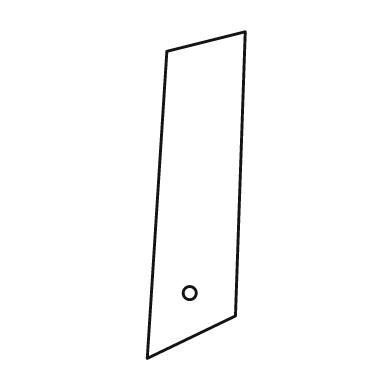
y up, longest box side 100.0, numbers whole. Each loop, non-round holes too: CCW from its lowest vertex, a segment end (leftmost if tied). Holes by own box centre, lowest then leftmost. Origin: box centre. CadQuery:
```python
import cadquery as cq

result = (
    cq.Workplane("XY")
    .moveTo(-15.0, -50.0)
    .lineTo(12.0, -37.0)
    .lineTo(15.0, 50.0)
    .lineTo(-9.0, 44.0)
    .close()
    .moveTo(-2.0, -30.0)
    .circle(2.0)
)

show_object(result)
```